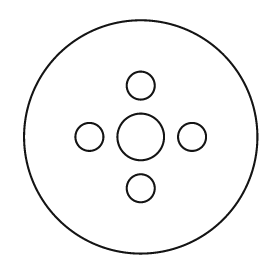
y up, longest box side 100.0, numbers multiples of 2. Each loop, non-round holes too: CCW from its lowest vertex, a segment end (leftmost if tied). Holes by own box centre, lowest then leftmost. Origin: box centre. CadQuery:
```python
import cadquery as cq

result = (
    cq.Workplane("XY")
    .moveTo(0.0, 0.0)
    .circle(50.0)
    .moveTo(0.0, -22.0)
    .circle(6.0)
    .moveTo(-22.0, 0.0)
    .circle(6.0)
    .moveTo(0.0, 0.0)
    .circle(10.0)
    .moveTo(22.0, 0.0)
    .circle(6.0)
    .moveTo(0.0, 22.0)
    .circle(6.0)
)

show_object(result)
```